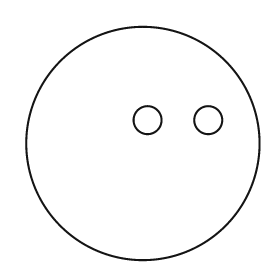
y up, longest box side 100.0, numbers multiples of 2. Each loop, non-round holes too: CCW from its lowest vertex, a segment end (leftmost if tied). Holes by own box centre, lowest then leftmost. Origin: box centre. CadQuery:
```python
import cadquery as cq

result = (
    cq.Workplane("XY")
    .moveTo(0.0, 0.0)
    .circle(50.0)
    .moveTo(2.0, 10.0)
    .circle(6.0)
    .moveTo(28.0, 10.0)
    .circle(6.0)
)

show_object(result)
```